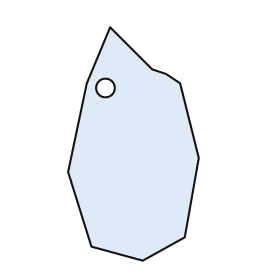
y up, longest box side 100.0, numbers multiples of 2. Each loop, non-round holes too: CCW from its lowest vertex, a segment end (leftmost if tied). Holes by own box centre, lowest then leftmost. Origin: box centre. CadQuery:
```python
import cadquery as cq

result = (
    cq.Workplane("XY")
    .moveTo(4.0, -50.0)
    .lineTo(22.0, -40.0)
    .lineTo(28.0, -6.0)
    .lineTo(20.0, 26.0)
    .lineTo(14.0, 30.0)
    .lineTo(8.0, 32.0)
    .lineTo(-10.0, 50.0)
    .lineTo(-20.0, 26.0)
    .lineTo(-28.0, -12.0)
    .lineTo(-18.0, -44.0)
    .close()
    .moveTo(-12.0, 24.0)
    .circle(4.0)
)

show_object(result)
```